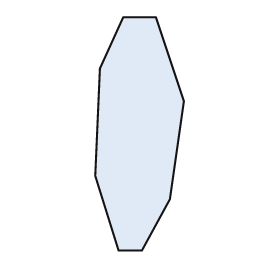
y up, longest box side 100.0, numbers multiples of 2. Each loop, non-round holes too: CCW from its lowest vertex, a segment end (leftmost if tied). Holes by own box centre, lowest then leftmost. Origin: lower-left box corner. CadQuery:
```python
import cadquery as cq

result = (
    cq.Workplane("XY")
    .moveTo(10.0, 0.0)
    .lineTo(20.0, 0.0)
    .lineTo(32.0, 22.0)
    .lineTo(38.0, 64.0)
    .lineTo(26.0, 100.0)
    .lineTo(12.0, 100.0)
    .lineTo(2.0, 78.0)
    .lineTo(0.0, 32.0)
    .close()
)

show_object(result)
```